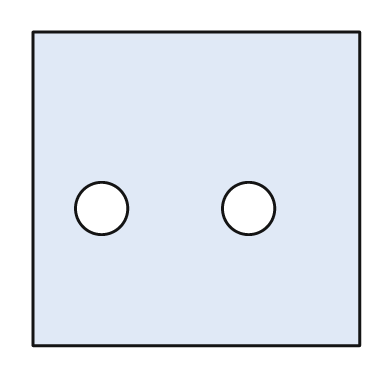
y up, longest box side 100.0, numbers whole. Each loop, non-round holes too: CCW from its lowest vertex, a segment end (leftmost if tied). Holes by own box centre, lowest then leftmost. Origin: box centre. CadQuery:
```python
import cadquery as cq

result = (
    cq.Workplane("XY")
    .moveTo(-50.0, -48.0)
    .lineTo(50.0, -48.0)
    .lineTo(50.0, 48.0)
    .lineTo(-50.0, 48.0)
    .close()
    .moveTo(-29.0, -6.0)
    .circle(8.0)
    .moveTo(16.0, -6.0)
    .circle(8.0)
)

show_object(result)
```